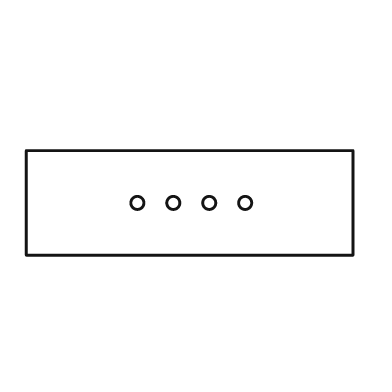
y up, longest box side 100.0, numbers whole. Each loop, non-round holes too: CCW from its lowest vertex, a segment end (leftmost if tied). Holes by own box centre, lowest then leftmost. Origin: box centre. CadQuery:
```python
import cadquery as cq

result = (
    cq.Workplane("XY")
    .moveTo(-50.0, -16.0)
    .lineTo(50.0, -16.0)
    .lineTo(50.0, 16.0)
    .lineTo(-50.0, 16.0)
    .close()
    .moveTo(-16.0, 0.0)
    .circle(2.0)
    .moveTo(-5.0, 0.0)
    .circle(2.0)
    .moveTo(6.0, 0.0)
    .circle(2.0)
    .moveTo(17.0, 0.0)
    .circle(2.0)
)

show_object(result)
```